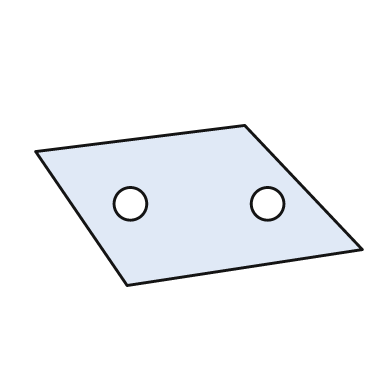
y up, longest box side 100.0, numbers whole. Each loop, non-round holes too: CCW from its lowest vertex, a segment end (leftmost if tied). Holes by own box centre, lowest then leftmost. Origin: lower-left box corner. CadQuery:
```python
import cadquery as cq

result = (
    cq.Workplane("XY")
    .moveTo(28.0, 0.0)
    .lineTo(100.0, 11.0)
    .lineTo(64.0, 49.0)
    .lineTo(0.0, 41.0)
    .close()
    .moveTo(29.0, 25.0)
    .circle(5.0)
    .moveTo(71.0, 25.0)
    .circle(5.0)
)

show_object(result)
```